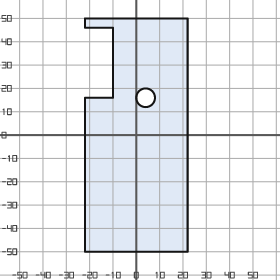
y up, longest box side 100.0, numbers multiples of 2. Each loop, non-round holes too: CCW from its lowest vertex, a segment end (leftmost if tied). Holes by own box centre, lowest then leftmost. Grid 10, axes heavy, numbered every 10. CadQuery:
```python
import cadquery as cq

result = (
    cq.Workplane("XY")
    .moveTo(-22.0, -50.0)
    .lineTo(22.0, -50.0)
    .lineTo(22.0, 50.0)
    .lineTo(-22.0, 50.0)
    .lineTo(-22.0, 46.0)
    .lineTo(-10.0, 46.0)
    .lineTo(-10.0, 16.0)
    .lineTo(-22.0, 16.0)
    .close()
    .moveTo(4.0, 16.0)
    .circle(4.0)
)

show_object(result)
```